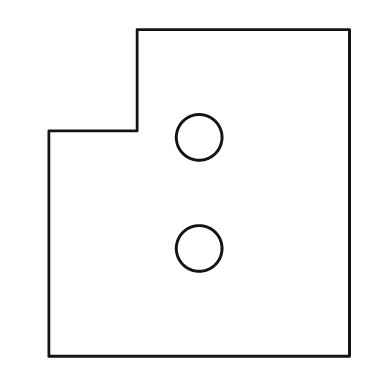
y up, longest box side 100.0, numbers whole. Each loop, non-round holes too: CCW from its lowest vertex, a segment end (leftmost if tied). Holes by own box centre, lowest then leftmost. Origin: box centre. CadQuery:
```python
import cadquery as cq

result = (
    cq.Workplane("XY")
    .moveTo(-46.0, -50.0)
    .lineTo(46.0, -50.0)
    .lineTo(46.0, 50.0)
    .lineTo(-19.0, 50.0)
    .lineTo(-19.0, 19.0)
    .lineTo(-46.0, 19.0)
    .close()
    .moveTo(0.0, -17.0)
    .circle(7.0)
    .moveTo(0.0, 17.0)
    .circle(7.0)
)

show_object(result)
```